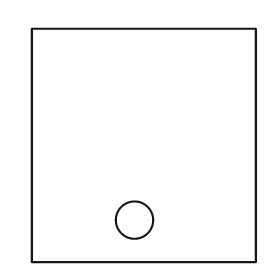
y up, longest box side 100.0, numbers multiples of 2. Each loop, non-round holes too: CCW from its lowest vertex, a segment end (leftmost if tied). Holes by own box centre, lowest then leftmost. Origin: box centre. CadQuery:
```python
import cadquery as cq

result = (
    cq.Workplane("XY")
    .moveTo(-48.0, -50.0)
    .lineTo(48.0, -50.0)
    .lineTo(48.0, 50.0)
    .lineTo(-48.0, 50.0)
    .close()
    .moveTo(-4.0, -32.0)
    .circle(8.0)
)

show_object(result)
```